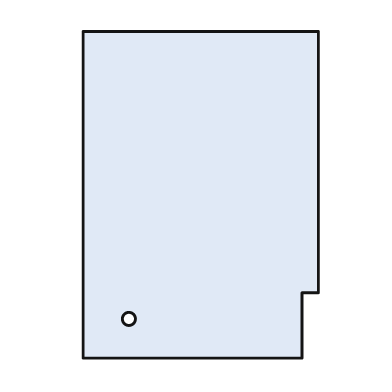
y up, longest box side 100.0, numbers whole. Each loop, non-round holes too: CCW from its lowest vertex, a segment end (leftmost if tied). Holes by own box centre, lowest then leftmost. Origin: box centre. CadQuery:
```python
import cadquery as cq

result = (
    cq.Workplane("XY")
    .moveTo(-36.0, -50.0)
    .lineTo(31.0, -50.0)
    .lineTo(31.0, -30.0)
    .lineTo(36.0, -30.0)
    .lineTo(36.0, 50.0)
    .lineTo(-36.0, 50.0)
    .close()
    .moveTo(-22.0, -38.0)
    .circle(2.0)
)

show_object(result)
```